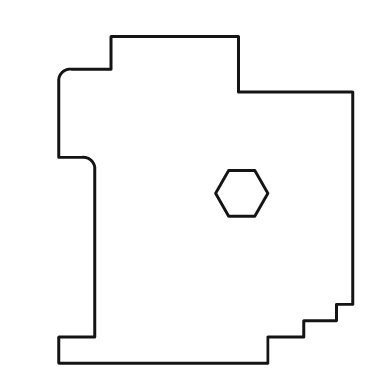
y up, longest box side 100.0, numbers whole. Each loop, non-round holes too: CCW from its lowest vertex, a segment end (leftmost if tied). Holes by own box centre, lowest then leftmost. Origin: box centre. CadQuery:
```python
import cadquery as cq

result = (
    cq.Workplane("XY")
    .moveTo(-45.0, -50.0)
    .lineTo(19.0, -50.0)
    .lineTo(19.0, -42.0)
    .lineTo(30.0, -42.0)
    .lineTo(30.0, -37.0)
    .lineTo(40.0, -37.0)
    .lineTo(40.0, -32.0)
    .lineTo(45.0, -32.0)
    .lineTo(45.0, 33.0)
    .lineTo(10.0, 33.0)
    .lineTo(10.0, 50.0)
    .lineTo(-29.0, 50.0)
    .lineTo(-29.0, 40.0)
    .lineTo(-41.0, 40.0)
    .threePointArc((-44.0, 39.0), (-45.0, 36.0))
    .lineTo(-45.0, 13.0)
    .lineTo(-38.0, 13.0)
    .threePointArc((-35.0, 12.0), (-34.0, 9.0))
    .lineTo(-34.0, -42.0)
    .lineTo(-45.0, -42.0)
    .close()
    .moveTo(7.0, -5.0)
    .lineTo(15.0, -5.0)
    .lineTo(19.0, 2.0)
    .lineTo(15.0, 9.0)
    .lineTo(7.0, 9.0)
    .lineTo(3.0, 2.0)
    .close()
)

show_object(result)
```